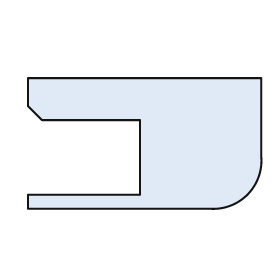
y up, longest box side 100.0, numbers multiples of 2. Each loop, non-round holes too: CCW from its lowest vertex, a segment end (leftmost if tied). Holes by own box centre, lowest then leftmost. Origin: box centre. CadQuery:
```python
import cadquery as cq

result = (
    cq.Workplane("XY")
    .moveTo(-50.0, -28.0)
    .lineTo(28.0, -28.0)
    .threePointArc((44.0, -22.0), (50.0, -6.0))
    .lineTo(50.0, 28.0)
    .lineTo(-50.0, 28.0)
    .lineTo(-50.0, 16.0)
    .lineTo(-44.0, 10.0)
    .lineTo(-2.0, 10.0)
    .lineTo(-2.0, -22.0)
    .lineTo(-50.0, -22.0)
    .close()
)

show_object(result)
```